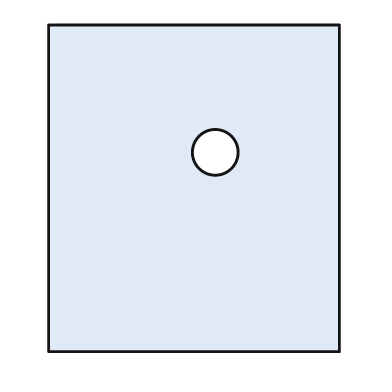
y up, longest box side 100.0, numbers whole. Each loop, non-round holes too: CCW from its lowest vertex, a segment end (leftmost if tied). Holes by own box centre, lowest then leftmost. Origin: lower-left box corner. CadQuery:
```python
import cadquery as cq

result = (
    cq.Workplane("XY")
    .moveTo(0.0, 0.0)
    .lineTo(89.0, 0.0)
    .lineTo(89.0, 100.0)
    .lineTo(0.0, 100.0)
    .close()
    .moveTo(51.0, 61.0)
    .circle(7.0)
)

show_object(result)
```